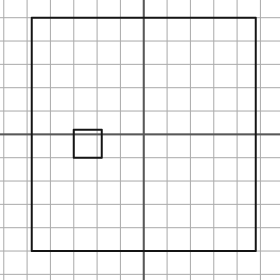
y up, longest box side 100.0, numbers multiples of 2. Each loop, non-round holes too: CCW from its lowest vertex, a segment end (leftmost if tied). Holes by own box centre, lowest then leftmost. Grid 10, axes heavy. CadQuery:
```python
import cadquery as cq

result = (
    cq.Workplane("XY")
    .moveTo(-48.0, -50.0)
    .lineTo(48.0, -50.0)
    .lineTo(48.0, 50.0)
    .lineTo(-48.0, 50.0)
    .close()
    .moveTo(-30.0, -10.0)
    .lineTo(-18.0, -10.0)
    .lineTo(-18.0, 2.0)
    .lineTo(-30.0, 2.0)
    .close()
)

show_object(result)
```